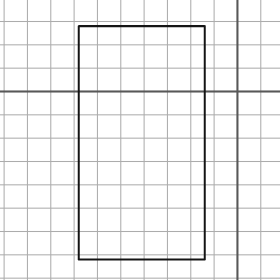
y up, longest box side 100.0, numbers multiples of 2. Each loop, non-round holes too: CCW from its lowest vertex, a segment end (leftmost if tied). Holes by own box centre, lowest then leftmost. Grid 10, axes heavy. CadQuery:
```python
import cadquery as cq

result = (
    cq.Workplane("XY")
    .moveTo(-68.0, -72.0)
    .lineTo(-14.0, -72.0)
    .lineTo(-14.0, 28.0)
    .lineTo(-68.0, 28.0)
    .close()
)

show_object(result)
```